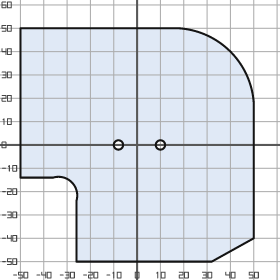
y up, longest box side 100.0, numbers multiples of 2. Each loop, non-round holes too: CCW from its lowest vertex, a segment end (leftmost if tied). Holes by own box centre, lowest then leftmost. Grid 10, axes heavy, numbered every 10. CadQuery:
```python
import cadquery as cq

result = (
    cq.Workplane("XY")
    .moveTo(-26.0, -50.0)
    .lineTo(32.0, -50.0)
    .lineTo(50.0, -40.0)
    .lineTo(50.0, 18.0)
    .threePointArc((40.0, 40.0), (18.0, 50.0))
    .lineTo(-50.0, 50.0)
    .lineTo(-50.0, -14.0)
    .lineTo(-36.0, -14.0)
    .threePointArc((-28.0, -16.0), (-26.0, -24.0))
    .close()
    .moveTo(-8.0, 0.0)
    .circle(2.0)
    .moveTo(10.0, 0.0)
    .circle(2.0)
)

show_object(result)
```